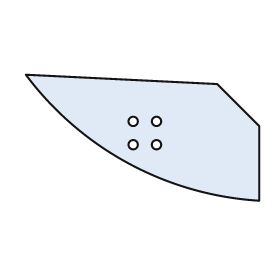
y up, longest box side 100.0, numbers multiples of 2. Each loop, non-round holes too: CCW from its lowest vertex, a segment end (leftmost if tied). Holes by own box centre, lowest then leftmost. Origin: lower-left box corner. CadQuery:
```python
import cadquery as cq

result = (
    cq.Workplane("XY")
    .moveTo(100.0, 0.0)
    .lineTo(100.0, 32.0)
    .lineTo(82.0, 50.0)
    .lineTo(0.0, 54.0)
    .threePointArc((44.0, 16.0), (100.0, 0.0))
    .close()
    .moveTo(46.0, 24.0)
    .circle(2.0)
    .moveTo(56.0, 24.0)
    .circle(2.0)
    .moveTo(46.0, 34.0)
    .circle(2.0)
    .moveTo(56.0, 34.0)
    .circle(2.0)
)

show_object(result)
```